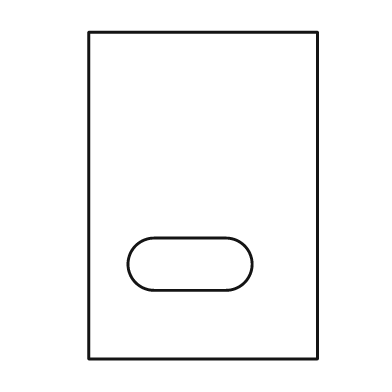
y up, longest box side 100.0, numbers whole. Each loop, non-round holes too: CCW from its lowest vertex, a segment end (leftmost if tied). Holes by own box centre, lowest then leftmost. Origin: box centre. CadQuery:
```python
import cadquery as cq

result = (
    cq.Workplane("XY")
    .moveTo(-35.0, -50.0)
    .lineTo(35.0, -50.0)
    .lineTo(35.0, 50.0)
    .lineTo(-35.0, 50.0)
    .close()
    .moveTo(-15.0, -29.0)
    .lineTo(7.0, -29.0)
    .threePointArc((15.0, -21.0), (7.0, -13.0))
    .lineTo(-15.0, -13.0)
    .threePointArc((-23.0, -21.0), (-15.0, -29.0))
    .close()
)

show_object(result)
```